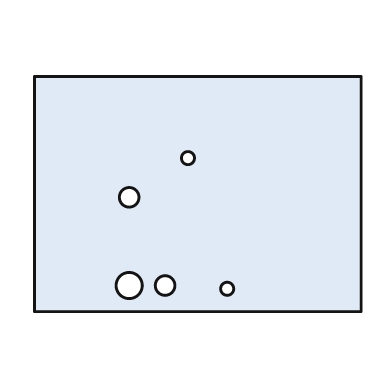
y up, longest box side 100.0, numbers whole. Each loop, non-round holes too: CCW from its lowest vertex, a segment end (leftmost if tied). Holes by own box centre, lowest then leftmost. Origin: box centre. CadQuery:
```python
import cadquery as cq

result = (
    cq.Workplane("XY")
    .moveTo(-50.0, -36.0)
    .lineTo(50.0, -36.0)
    .lineTo(50.0, 36.0)
    .lineTo(-50.0, 36.0)
    .close()
    .moveTo(9.0, -29.0)
    .circle(2.0)
    .moveTo(-21.0, -28.0)
    .circle(4.0)
    .moveTo(-10.0, -28.0)
    .circle(3.0)
    .moveTo(-21.0, -1.0)
    .circle(3.0)
    .moveTo(-3.0, 11.0)
    .circle(2.0)
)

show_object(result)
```